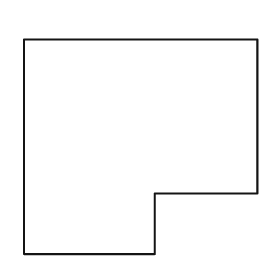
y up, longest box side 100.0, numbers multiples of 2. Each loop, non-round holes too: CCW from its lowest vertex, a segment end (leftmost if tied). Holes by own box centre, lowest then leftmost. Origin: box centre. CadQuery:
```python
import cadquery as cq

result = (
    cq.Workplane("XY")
    .moveTo(-50.0, -46.0)
    .lineTo(6.0, -46.0)
    .lineTo(6.0, -20.0)
    .lineTo(50.0, -20.0)
    .lineTo(50.0, 46.0)
    .lineTo(-50.0, 46.0)
    .close()
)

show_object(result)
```